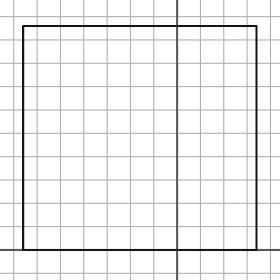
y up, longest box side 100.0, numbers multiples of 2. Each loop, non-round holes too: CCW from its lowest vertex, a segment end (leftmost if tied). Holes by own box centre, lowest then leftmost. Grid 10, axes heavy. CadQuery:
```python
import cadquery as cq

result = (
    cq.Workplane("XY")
    .moveTo(-66.0, 0.0)
    .lineTo(34.0, 0.0)
    .lineTo(34.0, 96.0)
    .lineTo(-66.0, 96.0)
    .close()
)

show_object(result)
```